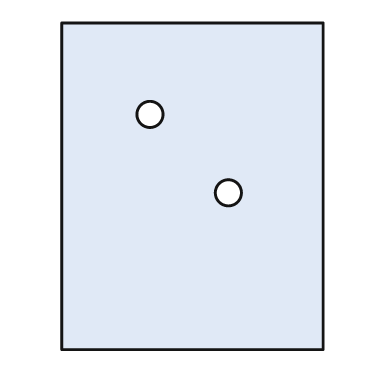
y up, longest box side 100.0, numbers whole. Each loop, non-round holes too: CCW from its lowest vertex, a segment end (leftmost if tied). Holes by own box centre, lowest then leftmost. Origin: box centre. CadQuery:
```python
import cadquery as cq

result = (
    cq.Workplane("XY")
    .moveTo(-40.0, -50.0)
    .lineTo(40.0, -50.0)
    .lineTo(40.0, 50.0)
    .lineTo(-40.0, 50.0)
    .close()
    .moveTo(11.0, -2.0)
    .circle(4.0)
    .moveTo(-13.0, 22.0)
    .circle(4.0)
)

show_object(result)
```